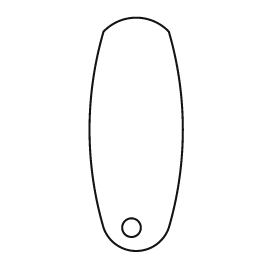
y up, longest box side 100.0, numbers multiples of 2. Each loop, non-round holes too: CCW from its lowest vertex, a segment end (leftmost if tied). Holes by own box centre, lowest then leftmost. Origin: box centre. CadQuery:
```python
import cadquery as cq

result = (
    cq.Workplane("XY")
    .moveTo(-14.0, -40.0)
    .threePointArc((0.0, -50.0), (14.0, -40.0))
    .threePointArc((20.0, 2.0), (14.0, 44.0))
    .threePointArc((0.0, 50.0), (-14.0, 44.0))
    .threePointArc((-20.0, 2.0), (-14.0, -40.0))
    .close()
    .moveTo(-2.0, -40.0)
    .circle(4.0)
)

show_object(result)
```